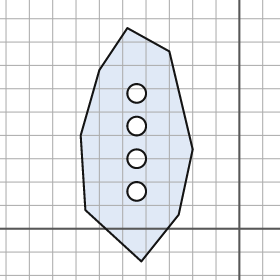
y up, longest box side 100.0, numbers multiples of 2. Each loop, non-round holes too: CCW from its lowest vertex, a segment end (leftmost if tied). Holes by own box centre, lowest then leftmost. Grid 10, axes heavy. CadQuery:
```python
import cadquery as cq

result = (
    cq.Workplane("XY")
    .moveTo(-42.0, -14.0)
    .lineTo(-26.0, 6.0)
    .lineTo(-20.0, 34.0)
    .lineTo(-30.0, 76.0)
    .lineTo(-48.0, 86.0)
    .lineTo(-60.0, 68.0)
    .lineTo(-68.0, 40.0)
    .lineTo(-66.0, 8.0)
    .close()
    .moveTo(-44.0, 16.0)
    .circle(4.0)
    .moveTo(-44.0, 30.0)
    .circle(4.0)
    .moveTo(-44.0, 44.0)
    .circle(4.0)
    .moveTo(-44.0, 58.0)
    .circle(4.0)
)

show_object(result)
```